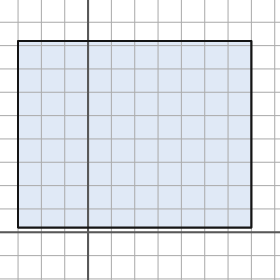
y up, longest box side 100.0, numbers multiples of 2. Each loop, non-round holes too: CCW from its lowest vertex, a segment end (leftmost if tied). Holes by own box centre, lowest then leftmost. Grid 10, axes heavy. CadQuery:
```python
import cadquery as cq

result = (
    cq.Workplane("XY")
    .moveTo(-30.0, 2.0)
    .lineTo(70.0, 2.0)
    .lineTo(70.0, 82.0)
    .lineTo(-30.0, 82.0)
    .close()
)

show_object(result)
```